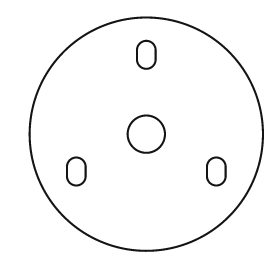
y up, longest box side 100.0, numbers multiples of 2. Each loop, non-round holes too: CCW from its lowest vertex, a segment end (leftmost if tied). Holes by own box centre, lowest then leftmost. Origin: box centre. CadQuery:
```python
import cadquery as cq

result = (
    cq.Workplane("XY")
    .moveTo(0.0, 0.0)
    .circle(50.0)
    .moveTo(-34.0, -18.0)
    .threePointArc((-30.0, -22.0), (-26.0, -18.0))
    .lineTo(-26.0, -14.0)
    .threePointArc((-30.0, -10.0), (-34.0, -14.0))
    .close()
    .moveTo(26.0, -18.0)
    .threePointArc((30.0, -22.0), (34.0, -18.0))
    .lineTo(34.0, -14.0)
    .threePointArc((30.0, -10.0), (26.0, -14.0))
    .close()
    .moveTo(0.0, 0.0)
    .circle(8.0)
    .moveTo(-4.0, 32.0)
    .threePointArc((0.0, 28.0), (4.0, 32.0))
    .lineTo(4.0, 36.0)
    .threePointArc((0.0, 40.0), (-4.0, 36.0))
    .close()
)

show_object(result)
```